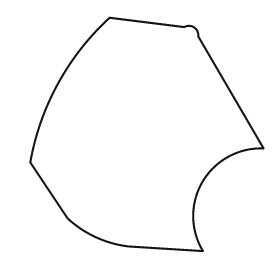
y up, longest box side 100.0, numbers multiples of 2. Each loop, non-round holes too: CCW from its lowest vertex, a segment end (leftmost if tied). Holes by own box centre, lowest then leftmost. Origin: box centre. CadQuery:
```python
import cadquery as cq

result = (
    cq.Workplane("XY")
    .moveTo(24.0, -50.0)
    .threePointArc((24.0, -20.0), (50.0, -6.0))
    .lineTo(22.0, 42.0)
    .threePointArc((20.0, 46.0), (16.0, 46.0))
    .lineTo(-16.0, 50.0)
    .threePointArc((-38.0, 22.0), (-50.0, -12.0))
    .lineTo(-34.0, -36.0)
    .threePointArc((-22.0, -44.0), (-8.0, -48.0))
    .close()
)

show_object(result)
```